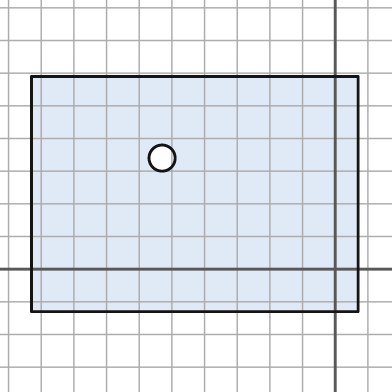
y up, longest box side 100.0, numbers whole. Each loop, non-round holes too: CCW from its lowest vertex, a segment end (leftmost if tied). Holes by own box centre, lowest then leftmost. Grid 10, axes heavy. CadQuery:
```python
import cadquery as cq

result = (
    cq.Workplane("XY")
    .moveTo(-93.0, -13.0)
    .lineTo(7.0, -13.0)
    .lineTo(7.0, 59.0)
    .lineTo(-93.0, 59.0)
    .close()
    .moveTo(-53.0, 34.0)
    .circle(4.0)
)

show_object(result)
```